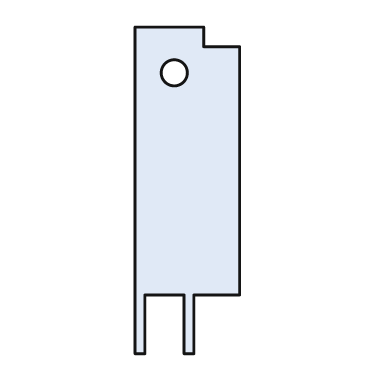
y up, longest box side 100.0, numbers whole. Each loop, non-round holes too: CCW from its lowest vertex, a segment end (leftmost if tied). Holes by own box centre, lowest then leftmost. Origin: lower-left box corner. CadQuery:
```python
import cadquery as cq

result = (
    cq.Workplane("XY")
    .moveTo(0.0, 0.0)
    .lineTo(3.0, 0.0)
    .lineTo(3.0, 18.0)
    .lineTo(15.0, 18.0)
    .lineTo(15.0, 0.0)
    .lineTo(18.0, 0.0)
    .lineTo(18.0, 18.0)
    .lineTo(32.0, 18.0)
    .lineTo(32.0, 94.0)
    .lineTo(21.0, 94.0)
    .lineTo(21.0, 100.0)
    .lineTo(0.0, 100.0)
    .close()
    .moveTo(12.0, 86.0)
    .circle(4.0)
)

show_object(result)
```